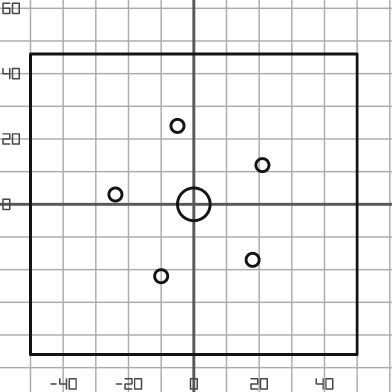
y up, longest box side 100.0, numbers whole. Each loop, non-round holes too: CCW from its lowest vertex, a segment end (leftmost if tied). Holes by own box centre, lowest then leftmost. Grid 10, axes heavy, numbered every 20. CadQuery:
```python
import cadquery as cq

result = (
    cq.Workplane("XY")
    .moveTo(-50.0, -46.0)
    .lineTo(50.0, -46.0)
    .lineTo(50.0, 46.0)
    .lineTo(-50.0, 46.0)
    .close()
    .moveTo(-10.0, -22.0)
    .circle(2.0)
    .moveTo(18.0, -17.0)
    .circle(2.0)
    .moveTo(0.0, 0.0)
    .circle(5.0)
    .moveTo(-24.0, 3.0)
    .circle(2.0)
    .moveTo(21.0, 12.0)
    .circle(2.0)
    .moveTo(-5.0, 24.0)
    .circle(2.0)
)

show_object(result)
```